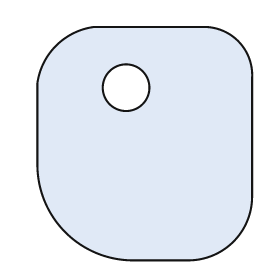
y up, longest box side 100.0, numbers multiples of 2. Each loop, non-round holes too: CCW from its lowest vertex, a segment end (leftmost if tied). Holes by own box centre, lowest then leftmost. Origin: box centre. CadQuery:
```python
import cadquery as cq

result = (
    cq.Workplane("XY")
    .moveTo(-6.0, -50.0)
    .lineTo(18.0, -50.0)
    .threePointArc((38.0, -42.0), (46.0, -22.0))
    .lineTo(46.0, 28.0)
    .threePointArc((40.0, 44.0), (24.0, 50.0))
    .lineTo(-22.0, 50.0)
    .threePointArc((-38.0, 42.0), (-46.0, 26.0))
    .lineTo(-46.0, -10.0)
    .threePointArc((-34.0, -38.0), (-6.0, -50.0))
    .close()
    .moveTo(-8.0, 24.0)
    .circle(10.0)
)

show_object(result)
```